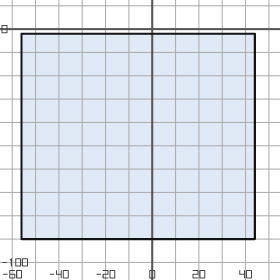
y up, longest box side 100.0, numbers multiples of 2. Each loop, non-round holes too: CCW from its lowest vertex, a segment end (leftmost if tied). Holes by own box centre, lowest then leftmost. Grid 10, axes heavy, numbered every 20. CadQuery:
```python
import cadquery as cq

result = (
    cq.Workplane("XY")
    .moveTo(-56.0, -90.0)
    .lineTo(44.0, -90.0)
    .lineTo(44.0, -2.0)
    .lineTo(-56.0, -2.0)
    .close()
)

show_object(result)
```